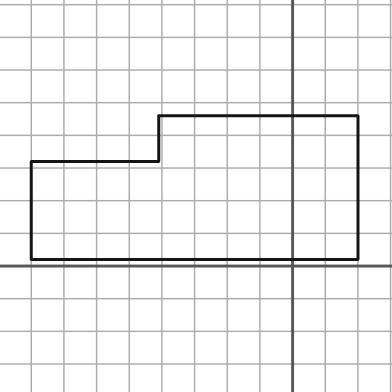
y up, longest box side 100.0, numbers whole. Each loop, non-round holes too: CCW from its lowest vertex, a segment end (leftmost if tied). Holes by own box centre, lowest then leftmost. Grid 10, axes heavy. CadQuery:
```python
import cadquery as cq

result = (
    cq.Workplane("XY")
    .moveTo(-80.0, 2.0)
    .lineTo(20.0, 2.0)
    .lineTo(20.0, 46.0)
    .lineTo(-41.0, 46.0)
    .lineTo(-41.0, 32.0)
    .lineTo(-80.0, 32.0)
    .close()
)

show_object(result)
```